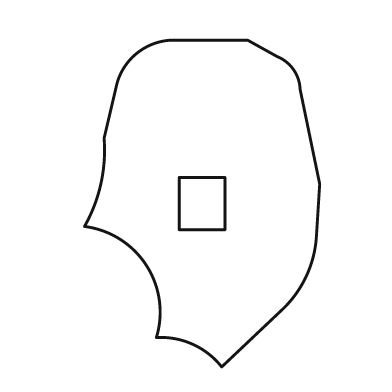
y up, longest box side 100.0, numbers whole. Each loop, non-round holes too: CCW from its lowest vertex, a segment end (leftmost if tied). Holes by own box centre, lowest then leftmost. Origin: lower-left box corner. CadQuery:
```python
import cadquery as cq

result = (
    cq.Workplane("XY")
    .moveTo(42.0, 0.0)
    .lineTo(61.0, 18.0)
    .threePointArc((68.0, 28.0), (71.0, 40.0))
    .lineTo(72.0, 56.0)
    .lineTo(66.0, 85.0)
    .threePointArc((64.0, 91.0), (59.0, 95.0))
    .lineTo(50.0, 100.0)
    .lineTo(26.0, 100.0)
    .threePointArc((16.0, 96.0), (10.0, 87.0))
    .lineTo(6.0, 70.0)
    .threePointArc((5.0, 56.0), (0.0, 43.0))
    .threePointArc((19.0, 31.0), (22.0, 9.0))
    .threePointArc((33.0, 7.0), (42.0, 0.0))
    .close()
    .moveTo(29.0, 42.0)
    .lineTo(43.0, 42.0)
    .lineTo(43.0, 58.0)
    .lineTo(29.0, 58.0)
    .close()
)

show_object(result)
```